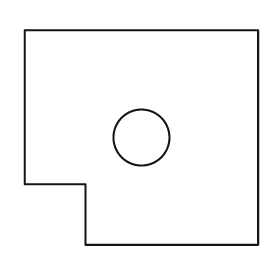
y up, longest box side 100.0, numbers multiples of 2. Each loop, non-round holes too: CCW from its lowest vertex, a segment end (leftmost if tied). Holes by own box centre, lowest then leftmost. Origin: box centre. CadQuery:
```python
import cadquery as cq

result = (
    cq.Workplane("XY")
    .moveTo(-24.0, -46.0)
    .lineTo(50.0, -46.0)
    .lineTo(50.0, 46.0)
    .lineTo(-50.0, 46.0)
    .lineTo(-50.0, -20.0)
    .lineTo(-24.0, -20.0)
    .close()
    .moveTo(0.0, 0.0)
    .circle(12.0)
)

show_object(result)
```